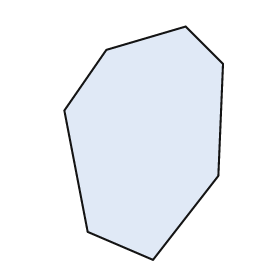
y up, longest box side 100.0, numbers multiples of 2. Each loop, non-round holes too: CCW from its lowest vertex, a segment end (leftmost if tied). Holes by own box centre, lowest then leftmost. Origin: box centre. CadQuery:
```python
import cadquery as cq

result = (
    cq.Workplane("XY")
    .moveTo(4.0, -50.0)
    .lineTo(32.0, -14.0)
    .lineTo(34.0, 34.0)
    .lineTo(18.0, 50.0)
    .lineTo(-16.0, 40.0)
    .lineTo(-34.0, 14.0)
    .lineTo(-24.0, -38.0)
    .close()
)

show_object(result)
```